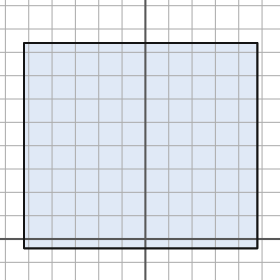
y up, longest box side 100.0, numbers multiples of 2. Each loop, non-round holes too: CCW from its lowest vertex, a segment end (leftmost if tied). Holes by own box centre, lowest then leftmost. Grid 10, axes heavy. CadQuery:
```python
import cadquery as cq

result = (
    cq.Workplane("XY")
    .moveTo(-52.0, -4.0)
    .lineTo(48.0, -4.0)
    .lineTo(48.0, 84.0)
    .lineTo(-52.0, 84.0)
    .close()
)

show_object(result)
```